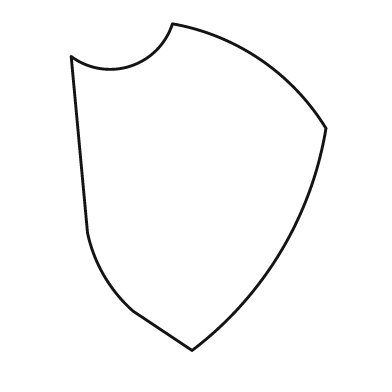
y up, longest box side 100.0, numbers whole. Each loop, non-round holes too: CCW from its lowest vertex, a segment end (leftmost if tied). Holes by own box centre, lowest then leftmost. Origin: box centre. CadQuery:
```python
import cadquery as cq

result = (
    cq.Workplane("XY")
    .moveTo(-2.0, -50.0)
    .threePointArc((25.0, -20.0), (39.0, 18.0))
    .threePointArc((19.0, 39.0), (-8.0, 50.0))
    .threePointArc((-21.0, 37.0), (-39.0, 40.0))
    .lineTo(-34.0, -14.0)
    .threePointArc((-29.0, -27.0), (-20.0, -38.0))
    .close()
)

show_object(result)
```